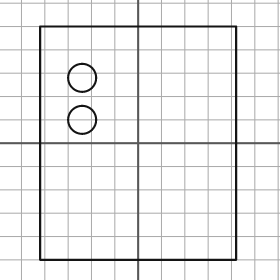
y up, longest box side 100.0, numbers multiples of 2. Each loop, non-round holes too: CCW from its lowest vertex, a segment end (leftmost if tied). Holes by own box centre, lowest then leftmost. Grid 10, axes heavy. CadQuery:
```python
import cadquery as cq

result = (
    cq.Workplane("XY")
    .moveTo(-42.0, -50.0)
    .lineTo(42.0, -50.0)
    .lineTo(42.0, 50.0)
    .lineTo(-42.0, 50.0)
    .close()
    .moveTo(-24.0, 10.0)
    .circle(6.0)
    .moveTo(-24.0, 28.0)
    .circle(6.0)
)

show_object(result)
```